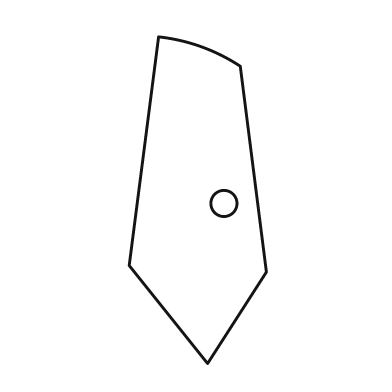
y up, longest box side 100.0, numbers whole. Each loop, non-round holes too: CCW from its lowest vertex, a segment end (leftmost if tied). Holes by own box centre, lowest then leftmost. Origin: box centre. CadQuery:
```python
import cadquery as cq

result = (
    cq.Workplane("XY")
    .moveTo(3.0, -50.0)
    .lineTo(21.0, -22.0)
    .lineTo(13.0, 41.0)
    .threePointArc((1.0, 47.0), (-12.0, 50.0))
    .lineTo(-21.0, -20.0)
    .close()
    .moveTo(8.0, -1.0)
    .circle(4.0)
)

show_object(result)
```